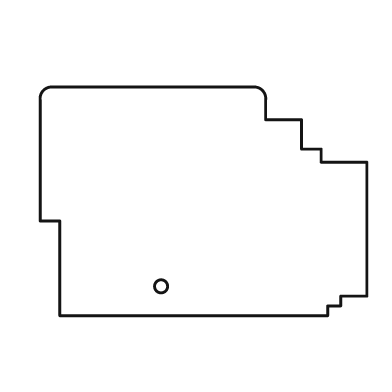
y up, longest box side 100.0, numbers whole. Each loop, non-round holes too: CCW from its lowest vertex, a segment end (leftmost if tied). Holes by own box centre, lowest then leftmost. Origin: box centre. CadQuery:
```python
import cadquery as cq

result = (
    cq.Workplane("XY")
    .moveTo(-44.0, -35.0)
    .lineTo(38.0, -35.0)
    .lineTo(38.0, -32.0)
    .lineTo(42.0, -32.0)
    .lineTo(42.0, -29.0)
    .lineTo(50.0, -29.0)
    .lineTo(50.0, 12.0)
    .lineTo(36.0, 12.0)
    .lineTo(36.0, 16.0)
    .lineTo(30.0, 16.0)
    .lineTo(30.0, 25.0)
    .lineTo(19.0, 25.0)
    .lineTo(19.0, 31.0)
    .threePointArc((18.0, 34.0), (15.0, 35.0))
    .lineTo(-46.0, 35.0)
    .threePointArc((-49.0, 34.0), (-50.0, 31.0))
    .lineTo(-50.0, -6.0)
    .lineTo(-44.0, -6.0)
    .close()
    .moveTo(-13.0, -26.0)
    .circle(2.0)
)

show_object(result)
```